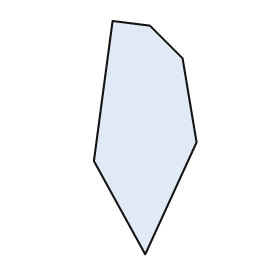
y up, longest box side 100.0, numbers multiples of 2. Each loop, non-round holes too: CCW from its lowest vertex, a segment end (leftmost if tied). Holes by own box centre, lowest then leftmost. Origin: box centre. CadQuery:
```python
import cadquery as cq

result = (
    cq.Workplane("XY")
    .moveTo(0.0, -50.0)
    .lineTo(22.0, -2.0)
    .lineTo(16.0, 34.0)
    .lineTo(2.0, 48.0)
    .lineTo(-14.0, 50.0)
    .lineTo(-22.0, -10.0)
    .close()
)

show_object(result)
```